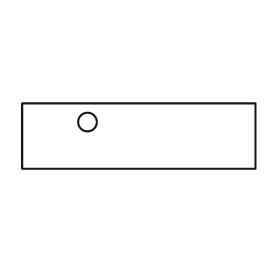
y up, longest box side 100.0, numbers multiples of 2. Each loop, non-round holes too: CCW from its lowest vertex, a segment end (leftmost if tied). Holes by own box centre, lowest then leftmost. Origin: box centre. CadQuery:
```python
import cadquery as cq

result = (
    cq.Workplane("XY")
    .moveTo(-50.0, -14.0)
    .lineTo(50.0, -14.0)
    .lineTo(50.0, 14.0)
    .lineTo(-50.0, 14.0)
    .close()
    .moveTo(-22.0, 6.0)
    .circle(4.0)
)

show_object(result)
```